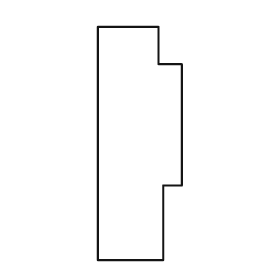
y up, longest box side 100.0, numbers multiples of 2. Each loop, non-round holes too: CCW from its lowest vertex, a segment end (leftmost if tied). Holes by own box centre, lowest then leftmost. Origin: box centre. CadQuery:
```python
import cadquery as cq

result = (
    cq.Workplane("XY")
    .moveTo(-18.0, -50.0)
    .lineTo(10.0, -50.0)
    .lineTo(10.0, -18.0)
    .lineTo(18.0, -18.0)
    .lineTo(18.0, 34.0)
    .lineTo(8.0, 34.0)
    .lineTo(8.0, 50.0)
    .lineTo(-18.0, 50.0)
    .close()
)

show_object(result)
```